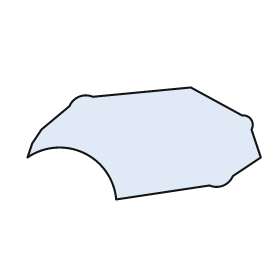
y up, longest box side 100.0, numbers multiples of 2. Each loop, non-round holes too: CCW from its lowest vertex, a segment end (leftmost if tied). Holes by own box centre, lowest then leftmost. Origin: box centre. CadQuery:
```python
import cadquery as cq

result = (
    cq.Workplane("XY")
    .moveTo(-12.0, -24.0)
    .lineTo(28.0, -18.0)
    .threePointArc((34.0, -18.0), (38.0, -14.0))
    .lineTo(50.0, -6.0)
    .lineTo(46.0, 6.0)
    .threePointArc((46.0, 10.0), (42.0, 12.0))
    .lineTo(20.0, 24.0)
    .lineTo(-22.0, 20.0)
    .threePointArc((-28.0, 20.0), (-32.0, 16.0))
    .lineTo(-44.0, 6.0)
    .lineTo(-48.0, 0.0)
    .lineTo(-50.0, -6.0)
    .threePointArc((-26.0, -4.0), (-12.0, -24.0))
    .close()
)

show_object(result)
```